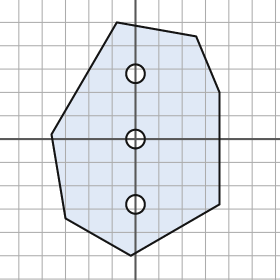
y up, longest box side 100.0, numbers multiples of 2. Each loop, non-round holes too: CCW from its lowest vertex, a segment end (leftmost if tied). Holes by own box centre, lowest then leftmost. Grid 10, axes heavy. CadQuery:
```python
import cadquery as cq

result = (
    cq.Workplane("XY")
    .moveTo(-2.0, -50.0)
    .lineTo(36.0, -28.0)
    .lineTo(36.0, 20.0)
    .lineTo(26.0, 44.0)
    .lineTo(-8.0, 50.0)
    .lineTo(-36.0, 2.0)
    .lineTo(-30.0, -34.0)
    .close()
    .moveTo(0.0, -28.0)
    .circle(4.0)
    .moveTo(0.0, 0.0)
    .circle(4.0)
    .moveTo(0.0, 28.0)
    .circle(4.0)
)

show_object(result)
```